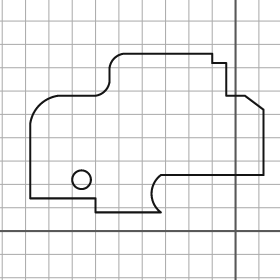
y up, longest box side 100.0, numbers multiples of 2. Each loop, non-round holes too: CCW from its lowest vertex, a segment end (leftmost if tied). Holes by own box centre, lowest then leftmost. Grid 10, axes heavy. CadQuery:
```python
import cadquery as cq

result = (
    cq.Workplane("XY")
    .moveTo(-60.0, 8.0)
    .lineTo(-32.0, 8.0)
    .threePointArc((-36.0, 16.0), (-32.0, 24.0))
    .lineTo(12.0, 24.0)
    .lineTo(12.0, 52.0)
    .lineTo(4.0, 58.0)
    .lineTo(-4.0, 58.0)
    .lineTo(-4.0, 72.0)
    .lineTo(-10.0, 72.0)
    .lineTo(-10.0, 76.0)
    .lineTo(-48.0, 76.0)
    .threePointArc((-52.0, 74.0), (-54.0, 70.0))
    .lineTo(-54.0, 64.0)
    .threePointArc((-56.0, 60.0), (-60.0, 58.0))
    .lineTo(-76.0, 58.0)
    .threePointArc((-84.0, 54.0), (-88.0, 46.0))
    .lineTo(-88.0, 14.0)
    .lineTo(-60.0, 14.0)
    .close()
    .moveTo(-66.0, 22.0)
    .circle(4.0)
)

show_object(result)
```